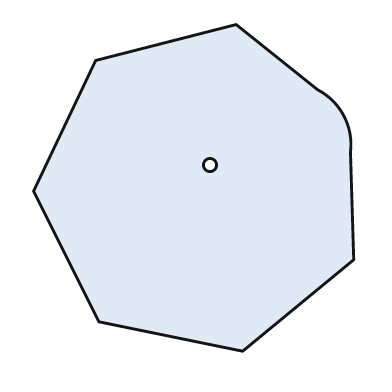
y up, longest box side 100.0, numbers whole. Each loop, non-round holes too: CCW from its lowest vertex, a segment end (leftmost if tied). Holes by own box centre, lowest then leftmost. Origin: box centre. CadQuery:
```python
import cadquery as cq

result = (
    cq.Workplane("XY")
    .moveTo(15.0, -50.0)
    .lineTo(49.0, -22.0)
    .lineTo(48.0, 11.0)
    .threePointArc((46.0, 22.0), (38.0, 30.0))
    .lineTo(13.0, 50.0)
    .lineTo(-30.0, 39.0)
    .lineTo(-49.0, -1.0)
    .lineTo(-29.0, -41.0)
    .close()
    .moveTo(5.0, 7.0)
    .circle(2.0)
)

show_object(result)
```